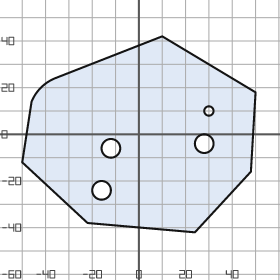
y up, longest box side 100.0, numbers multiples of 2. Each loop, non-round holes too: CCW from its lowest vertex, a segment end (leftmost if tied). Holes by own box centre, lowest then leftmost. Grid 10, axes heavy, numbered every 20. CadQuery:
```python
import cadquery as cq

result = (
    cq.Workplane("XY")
    .moveTo(24.0, -42.0)
    .lineTo(48.0, -16.0)
    .lineTo(50.0, 18.0)
    .lineTo(10.0, 42.0)
    .lineTo(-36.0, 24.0)
    .threePointArc((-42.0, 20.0), (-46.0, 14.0))
    .lineTo(-50.0, -12.0)
    .lineTo(-22.0, -38.0)
    .close()
    .moveTo(-16.0, -24.0)
    .circle(4.0)
    .moveTo(-12.0, -6.0)
    .circle(4.0)
    .moveTo(28.0, -4.0)
    .circle(4.0)
    .moveTo(30.0, 10.0)
    .circle(2.0)
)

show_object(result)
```